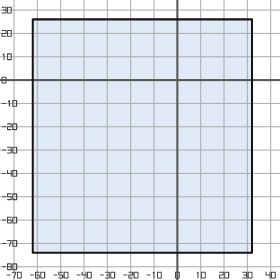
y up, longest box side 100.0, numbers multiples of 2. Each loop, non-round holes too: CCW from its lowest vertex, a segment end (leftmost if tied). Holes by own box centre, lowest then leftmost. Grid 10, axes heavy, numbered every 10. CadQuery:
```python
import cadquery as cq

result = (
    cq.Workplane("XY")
    .moveTo(-62.0, -74.0)
    .lineTo(32.0, -74.0)
    .lineTo(32.0, 26.0)
    .lineTo(-62.0, 26.0)
    .close()
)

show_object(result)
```